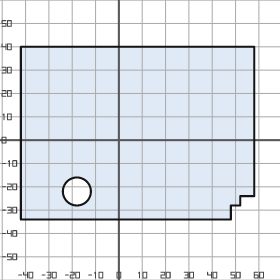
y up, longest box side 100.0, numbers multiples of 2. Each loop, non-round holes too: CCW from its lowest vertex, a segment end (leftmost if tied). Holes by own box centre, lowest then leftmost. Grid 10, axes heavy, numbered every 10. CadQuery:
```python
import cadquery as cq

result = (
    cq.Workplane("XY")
    .moveTo(-42.0, -34.0)
    .lineTo(48.0, -34.0)
    .lineTo(48.0, -28.0)
    .lineTo(52.0, -28.0)
    .lineTo(52.0, -24.0)
    .lineTo(58.0, -24.0)
    .lineTo(58.0, 40.0)
    .lineTo(-42.0, 40.0)
    .close()
    .moveTo(-18.0, -22.0)
    .circle(6.0)
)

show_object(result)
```